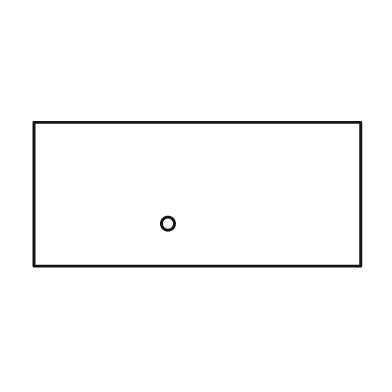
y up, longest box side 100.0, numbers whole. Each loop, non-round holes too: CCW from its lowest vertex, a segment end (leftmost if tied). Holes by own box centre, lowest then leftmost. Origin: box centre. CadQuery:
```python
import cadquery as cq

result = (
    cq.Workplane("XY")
    .moveTo(-50.0, -22.0)
    .lineTo(50.0, -22.0)
    .lineTo(50.0, 22.0)
    .lineTo(-50.0, 22.0)
    .close()
    .moveTo(-9.0, -9.0)
    .circle(2.0)
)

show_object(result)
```